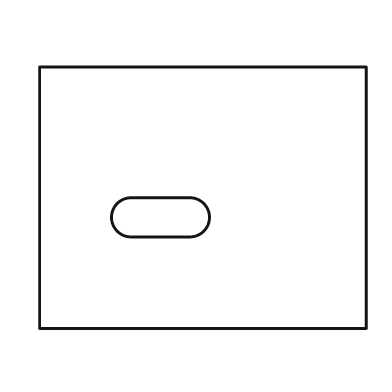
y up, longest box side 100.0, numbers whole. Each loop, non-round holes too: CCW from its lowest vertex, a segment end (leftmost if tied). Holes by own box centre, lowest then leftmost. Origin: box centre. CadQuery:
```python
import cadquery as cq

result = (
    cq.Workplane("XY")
    .moveTo(-50.0, -40.0)
    .lineTo(50.0, -40.0)
    .lineTo(50.0, 40.0)
    .lineTo(-50.0, 40.0)
    .close()
    .moveTo(-22.0, -12.0)
    .lineTo(-4.0, -12.0)
    .threePointArc((2.0, -6.0), (-4.0, 0.0))
    .lineTo(-22.0, 0.0)
    .threePointArc((-28.0, -6.0), (-22.0, -12.0))
    .close()
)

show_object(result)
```